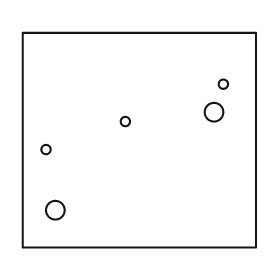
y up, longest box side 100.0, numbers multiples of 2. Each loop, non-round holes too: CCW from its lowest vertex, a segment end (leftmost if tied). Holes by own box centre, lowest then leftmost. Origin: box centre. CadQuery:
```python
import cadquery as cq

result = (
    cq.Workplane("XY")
    .moveTo(-50.0, -46.0)
    .lineTo(50.0, -46.0)
    .lineTo(50.0, 46.0)
    .lineTo(-50.0, 46.0)
    .close()
    .moveTo(-36.0, -30.0)
    .circle(4.0)
    .moveTo(-40.0, -4.0)
    .circle(2.0)
    .moveTo(-6.0, 8.0)
    .circle(2.0)
    .moveTo(32.0, 12.0)
    .circle(4.0)
    .moveTo(36.0, 24.0)
    .circle(2.0)
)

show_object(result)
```